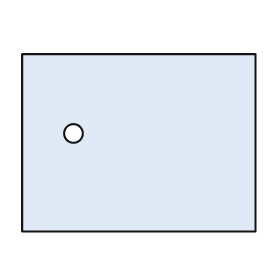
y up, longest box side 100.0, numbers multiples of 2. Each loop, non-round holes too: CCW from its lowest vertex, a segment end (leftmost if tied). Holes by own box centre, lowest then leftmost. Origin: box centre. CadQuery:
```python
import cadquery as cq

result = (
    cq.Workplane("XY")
    .moveTo(-50.0, -38.0)
    .lineTo(50.0, -38.0)
    .lineTo(50.0, 38.0)
    .lineTo(-50.0, 38.0)
    .close()
    .moveTo(-28.0, 4.0)
    .circle(4.0)
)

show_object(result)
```